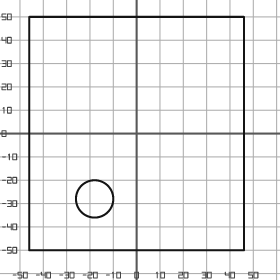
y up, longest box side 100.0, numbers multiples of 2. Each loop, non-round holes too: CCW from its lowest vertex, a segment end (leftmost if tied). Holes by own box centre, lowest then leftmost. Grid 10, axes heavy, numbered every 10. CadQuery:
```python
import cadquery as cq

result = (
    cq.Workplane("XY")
    .moveTo(-46.0, -50.0)
    .lineTo(46.0, -50.0)
    .lineTo(46.0, 50.0)
    .lineTo(-46.0, 50.0)
    .close()
    .moveTo(-18.0, -28.0)
    .circle(8.0)
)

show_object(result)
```